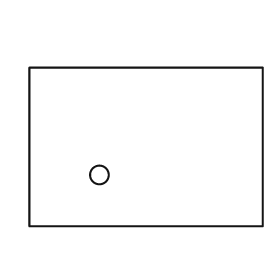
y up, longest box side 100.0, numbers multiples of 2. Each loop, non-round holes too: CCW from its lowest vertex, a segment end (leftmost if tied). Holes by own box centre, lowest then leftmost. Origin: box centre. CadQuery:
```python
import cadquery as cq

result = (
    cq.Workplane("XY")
    .moveTo(-50.0, -34.0)
    .lineTo(50.0, -34.0)
    .lineTo(50.0, 34.0)
    .lineTo(-50.0, 34.0)
    .close()
    .moveTo(-20.0, -12.0)
    .circle(4.0)
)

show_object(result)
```